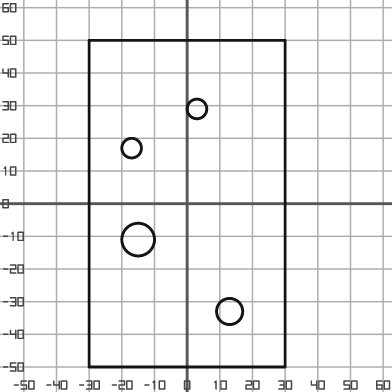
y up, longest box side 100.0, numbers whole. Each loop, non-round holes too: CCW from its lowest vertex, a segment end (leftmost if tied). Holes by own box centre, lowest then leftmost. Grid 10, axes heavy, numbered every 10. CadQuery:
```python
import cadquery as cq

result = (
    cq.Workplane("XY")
    .moveTo(-30.0, -50.0)
    .lineTo(30.0, -50.0)
    .lineTo(30.0, 50.0)
    .lineTo(-30.0, 50.0)
    .close()
    .moveTo(13.0, -33.0)
    .circle(4.0)
    .moveTo(-15.0, -11.0)
    .circle(5.0)
    .moveTo(-17.0, 17.0)
    .circle(3.0)
    .moveTo(3.0, 29.0)
    .circle(3.0)
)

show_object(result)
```